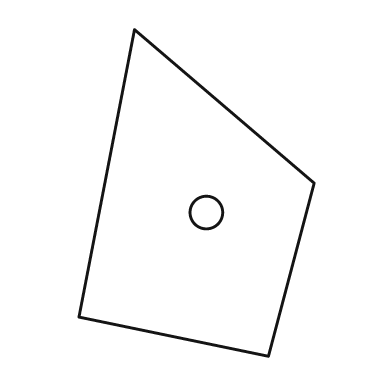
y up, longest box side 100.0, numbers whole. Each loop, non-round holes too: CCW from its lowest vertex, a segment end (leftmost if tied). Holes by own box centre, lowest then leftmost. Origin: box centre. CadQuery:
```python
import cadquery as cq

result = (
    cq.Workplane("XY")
    .moveTo(22.0, -50.0)
    .lineTo(36.0, 3.0)
    .lineTo(-19.0, 50.0)
    .lineTo(-36.0, -38.0)
    .close()
    .moveTo(3.0, -6.0)
    .circle(5.0)
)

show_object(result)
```